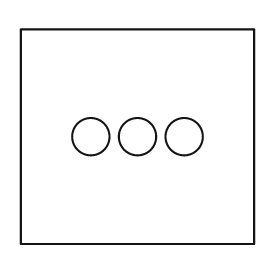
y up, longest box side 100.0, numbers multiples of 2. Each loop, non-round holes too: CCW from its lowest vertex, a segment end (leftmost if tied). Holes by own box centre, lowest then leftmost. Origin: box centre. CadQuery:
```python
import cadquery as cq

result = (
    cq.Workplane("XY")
    .moveTo(-50.0, -46.0)
    .lineTo(50.0, -46.0)
    .lineTo(50.0, 46.0)
    .lineTo(-50.0, 46.0)
    .close()
    .moveTo(-20.0, 0.0)
    .circle(8.0)
    .moveTo(0.0, 0.0)
    .circle(8.0)
    .moveTo(20.0, 0.0)
    .circle(8.0)
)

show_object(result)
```